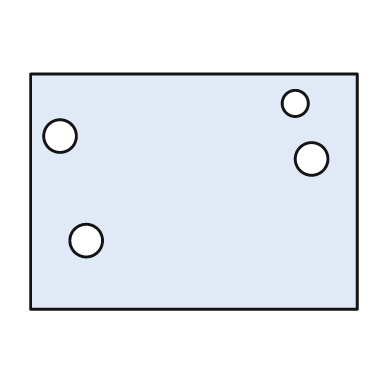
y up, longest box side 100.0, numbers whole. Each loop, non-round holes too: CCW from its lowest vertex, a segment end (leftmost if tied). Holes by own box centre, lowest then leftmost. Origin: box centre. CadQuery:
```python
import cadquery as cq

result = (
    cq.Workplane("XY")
    .moveTo(-50.0, -36.0)
    .lineTo(50.0, -36.0)
    .lineTo(50.0, 36.0)
    .lineTo(-50.0, 36.0)
    .close()
    .moveTo(-33.0, -15.0)
    .circle(5.0)
    .moveTo(36.0, 10.0)
    .circle(5.0)
    .moveTo(-41.0, 17.0)
    .circle(5.0)
    .moveTo(31.0, 27.0)
    .circle(4.0)
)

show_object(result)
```